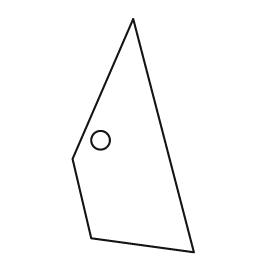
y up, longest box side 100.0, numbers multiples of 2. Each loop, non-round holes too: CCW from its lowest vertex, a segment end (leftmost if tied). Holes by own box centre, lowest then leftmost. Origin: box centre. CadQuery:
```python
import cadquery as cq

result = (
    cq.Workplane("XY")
    .moveTo(26.0, -50.0)
    .lineTo(0.0, 50.0)
    .lineTo(-26.0, -10.0)
    .lineTo(-18.0, -44.0)
    .close()
    .moveTo(-14.0, -2.0)
    .circle(4.0)
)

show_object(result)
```